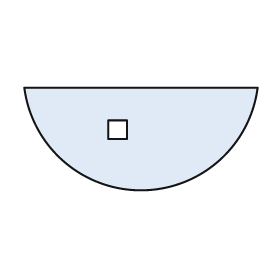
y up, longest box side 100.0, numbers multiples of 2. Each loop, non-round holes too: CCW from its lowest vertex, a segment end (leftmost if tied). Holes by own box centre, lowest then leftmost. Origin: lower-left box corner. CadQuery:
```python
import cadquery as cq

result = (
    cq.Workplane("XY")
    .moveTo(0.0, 44.0)
    .threePointArc((50.0, 0.0), (100.0, 44.0))
    .close()
    .moveTo(36.0, 22.0)
    .lineTo(44.0, 22.0)
    .lineTo(44.0, 30.0)
    .lineTo(36.0, 30.0)
    .close()
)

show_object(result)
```